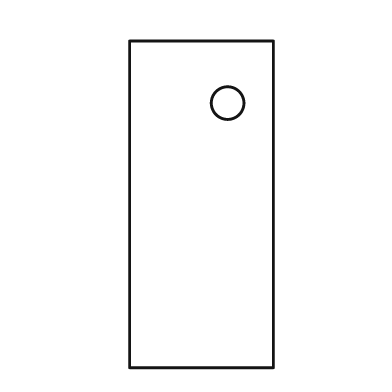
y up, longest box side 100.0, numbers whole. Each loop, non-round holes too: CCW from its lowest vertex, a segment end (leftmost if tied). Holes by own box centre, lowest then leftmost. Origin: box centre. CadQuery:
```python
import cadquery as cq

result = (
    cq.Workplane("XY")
    .moveTo(-22.0, -50.0)
    .lineTo(22.0, -50.0)
    .lineTo(22.0, 50.0)
    .lineTo(-22.0, 50.0)
    .close()
    .moveTo(8.0, 31.0)
    .circle(5.0)
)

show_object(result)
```